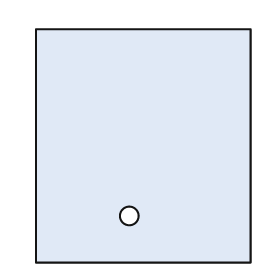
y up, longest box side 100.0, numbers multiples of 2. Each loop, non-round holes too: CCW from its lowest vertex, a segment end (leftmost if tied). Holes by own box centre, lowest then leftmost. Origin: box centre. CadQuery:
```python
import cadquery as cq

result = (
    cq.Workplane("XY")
    .moveTo(-46.0, -50.0)
    .lineTo(46.0, -50.0)
    .lineTo(46.0, 50.0)
    .lineTo(-46.0, 50.0)
    .close()
    .moveTo(-6.0, -30.0)
    .circle(4.0)
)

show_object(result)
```